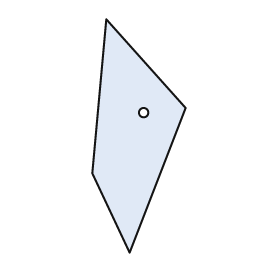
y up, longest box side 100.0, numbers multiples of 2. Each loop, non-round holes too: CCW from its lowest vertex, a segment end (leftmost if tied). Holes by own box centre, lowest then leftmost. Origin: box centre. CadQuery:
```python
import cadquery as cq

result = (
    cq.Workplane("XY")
    .moveTo(-4.0, -50.0)
    .lineTo(20.0, 12.0)
    .lineTo(-14.0, 50.0)
    .lineTo(-20.0, -16.0)
    .close()
    .moveTo(2.0, 10.0)
    .circle(2.0)
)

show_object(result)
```